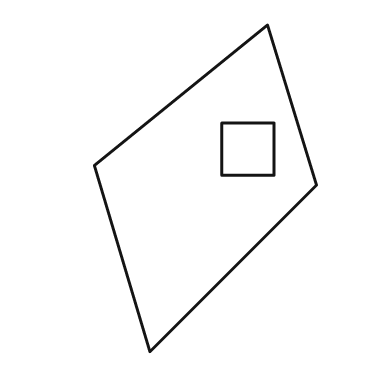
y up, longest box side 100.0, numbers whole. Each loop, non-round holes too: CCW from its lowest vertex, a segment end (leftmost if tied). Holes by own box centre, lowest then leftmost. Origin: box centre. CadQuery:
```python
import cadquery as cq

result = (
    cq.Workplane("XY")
    .moveTo(-17.0, -50.0)
    .lineTo(34.0, 1.0)
    .lineTo(19.0, 50.0)
    .lineTo(-34.0, 7.0)
    .close()
    .moveTo(5.0, 4.0)
    .lineTo(21.0, 4.0)
    .lineTo(21.0, 20.0)
    .lineTo(5.0, 20.0)
    .close()
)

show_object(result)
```